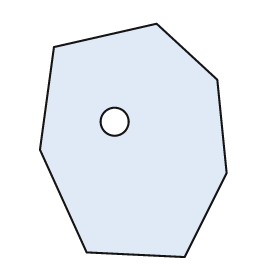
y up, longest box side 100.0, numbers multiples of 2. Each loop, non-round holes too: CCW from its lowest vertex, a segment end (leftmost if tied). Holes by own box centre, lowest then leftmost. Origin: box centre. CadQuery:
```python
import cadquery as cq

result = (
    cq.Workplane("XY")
    .moveTo(22.0, -50.0)
    .lineTo(40.0, -14.0)
    .lineTo(36.0, 26.0)
    .lineTo(10.0, 50.0)
    .lineTo(-34.0, 40.0)
    .lineTo(-40.0, -4.0)
    .lineTo(-20.0, -48.0)
    .close()
    .moveTo(-8.0, 8.0)
    .circle(6.0)
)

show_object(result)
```